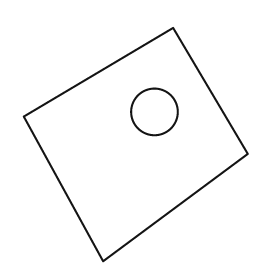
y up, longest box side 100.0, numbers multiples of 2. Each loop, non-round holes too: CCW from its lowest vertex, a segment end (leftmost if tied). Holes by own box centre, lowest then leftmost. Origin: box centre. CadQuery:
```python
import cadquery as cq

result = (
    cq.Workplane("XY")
    .moveTo(-14.0, -50.0)
    .lineTo(48.0, -4.0)
    .lineTo(16.0, 50.0)
    .lineTo(-48.0, 12.0)
    .close()
    .moveTo(8.0, 14.0)
    .circle(10.0)
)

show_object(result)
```